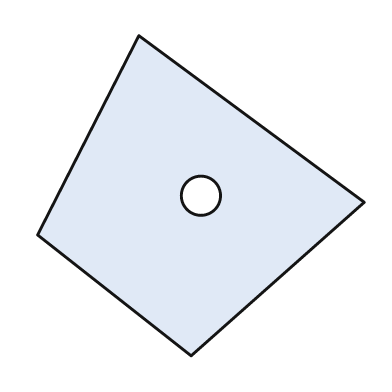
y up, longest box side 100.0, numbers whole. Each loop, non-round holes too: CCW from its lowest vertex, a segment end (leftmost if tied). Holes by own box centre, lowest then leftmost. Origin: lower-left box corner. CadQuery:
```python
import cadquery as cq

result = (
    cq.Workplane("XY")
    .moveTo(47.0, 0.0)
    .lineTo(100.0, 47.0)
    .lineTo(31.0, 98.0)
    .lineTo(0.0, 37.0)
    .close()
    .moveTo(50.0, 49.0)
    .circle(6.0)
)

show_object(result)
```